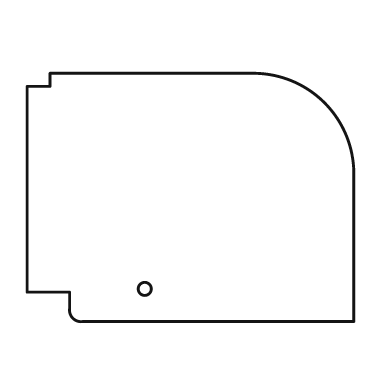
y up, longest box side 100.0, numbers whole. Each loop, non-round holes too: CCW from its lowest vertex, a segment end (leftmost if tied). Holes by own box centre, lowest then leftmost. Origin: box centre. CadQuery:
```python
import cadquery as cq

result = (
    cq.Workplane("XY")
    .moveTo(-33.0, -38.0)
    .lineTo(50.0, -38.0)
    .lineTo(50.0, 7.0)
    .threePointArc((41.0, 29.0), (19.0, 38.0))
    .lineTo(-43.0, 38.0)
    .lineTo(-43.0, 34.0)
    .lineTo(-50.0, 34.0)
    .lineTo(-50.0, -29.0)
    .lineTo(-37.0, -29.0)
    .lineTo(-37.0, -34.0)
    .threePointArc((-36.0, -37.0), (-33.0, -38.0))
    .close()
    .moveTo(-14.0, -28.0)
    .circle(2.0)
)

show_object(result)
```